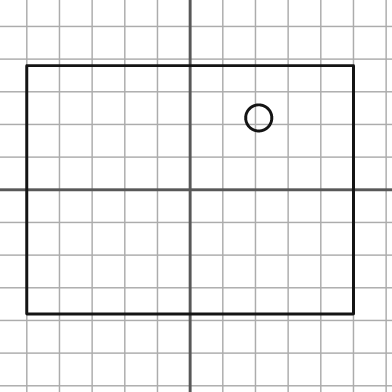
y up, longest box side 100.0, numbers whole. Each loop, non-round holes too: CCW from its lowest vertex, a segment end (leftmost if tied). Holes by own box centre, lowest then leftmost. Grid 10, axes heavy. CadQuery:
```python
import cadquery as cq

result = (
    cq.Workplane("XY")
    .moveTo(-50.0, -38.0)
    .lineTo(50.0, -38.0)
    .lineTo(50.0, 38.0)
    .lineTo(-50.0, 38.0)
    .close()
    .moveTo(21.0, 22.0)
    .circle(4.0)
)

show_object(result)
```